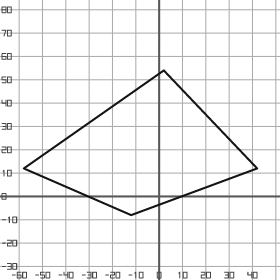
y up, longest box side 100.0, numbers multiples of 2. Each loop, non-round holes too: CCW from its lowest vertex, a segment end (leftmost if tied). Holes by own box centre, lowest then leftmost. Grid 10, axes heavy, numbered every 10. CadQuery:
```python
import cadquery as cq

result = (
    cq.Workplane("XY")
    .moveTo(-12.0, -8.0)
    .lineTo(42.0, 12.0)
    .lineTo(2.0, 54.0)
    .lineTo(-58.0, 12.0)
    .close()
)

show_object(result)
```